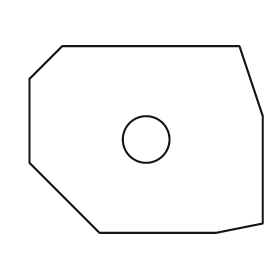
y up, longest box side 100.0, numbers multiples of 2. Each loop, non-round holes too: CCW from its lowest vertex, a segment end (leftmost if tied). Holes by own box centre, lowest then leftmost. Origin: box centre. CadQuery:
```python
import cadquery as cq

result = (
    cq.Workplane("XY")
    .moveTo(-20.0, -40.0)
    .lineTo(30.0, -40.0)
    .lineTo(50.0, -36.0)
    .lineTo(50.0, 10.0)
    .lineTo(40.0, 40.0)
    .lineTo(-36.0, 40.0)
    .lineTo(-50.0, 26.0)
    .lineTo(-50.0, -10.0)
    .close()
    .moveTo(0.0, 0.0)
    .circle(10.0)
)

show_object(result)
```